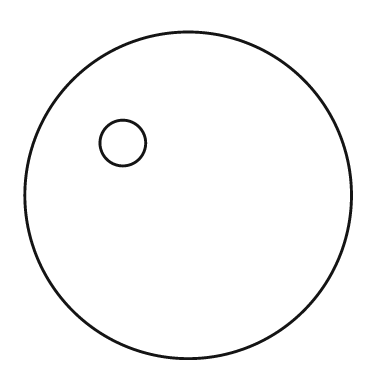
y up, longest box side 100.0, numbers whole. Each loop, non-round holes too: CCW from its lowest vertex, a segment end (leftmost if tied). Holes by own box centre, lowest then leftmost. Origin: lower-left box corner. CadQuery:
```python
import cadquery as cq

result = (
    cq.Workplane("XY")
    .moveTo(50.0, 50.0)
    .circle(50.0)
    .moveTo(30.0, 66.0)
    .circle(7.0)
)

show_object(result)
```